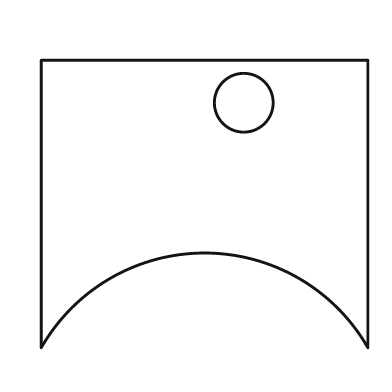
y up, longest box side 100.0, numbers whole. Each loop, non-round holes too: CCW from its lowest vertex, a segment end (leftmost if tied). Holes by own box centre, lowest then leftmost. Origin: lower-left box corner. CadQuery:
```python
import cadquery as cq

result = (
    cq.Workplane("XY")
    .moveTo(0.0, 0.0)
    .threePointArc((50.0, 29.0), (100.0, 0.0))
    .lineTo(100.0, 88.0)
    .lineTo(0.0, 88.0)
    .close()
    .moveTo(62.0, 75.0)
    .circle(9.0)
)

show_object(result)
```